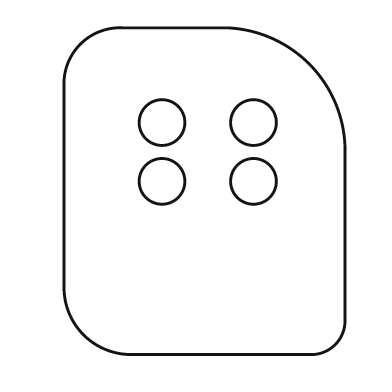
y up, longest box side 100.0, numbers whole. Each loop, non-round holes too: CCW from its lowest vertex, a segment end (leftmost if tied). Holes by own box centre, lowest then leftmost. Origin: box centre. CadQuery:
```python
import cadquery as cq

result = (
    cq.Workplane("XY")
    .moveTo(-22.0, -50.0)
    .lineTo(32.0, -50.0)
    .threePointArc((40.0, -47.0), (43.0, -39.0))
    .lineTo(43.0, 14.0)
    .threePointArc((32.0, 39.0), (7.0, 50.0))
    .lineTo(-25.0, 50.0)
    .threePointArc((-38.0, 45.0), (-43.0, 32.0))
    .lineTo(-43.0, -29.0)
    .threePointArc((-37.0, -44.0), (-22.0, -50.0))
    .close()
    .moveTo(-13.0, 3.0)
    .circle(7.0)
    .moveTo(15.0, 3.0)
    .circle(7.0)
    .moveTo(-13.0, 21.0)
    .circle(7.0)
    .moveTo(15.0, 21.0)
    .circle(7.0)
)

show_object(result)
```